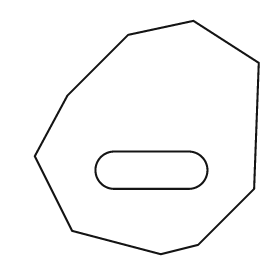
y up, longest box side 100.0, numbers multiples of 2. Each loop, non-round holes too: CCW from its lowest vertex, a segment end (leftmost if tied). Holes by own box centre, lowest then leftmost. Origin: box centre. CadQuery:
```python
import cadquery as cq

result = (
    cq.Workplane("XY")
    .moveTo(6.0, -50.0)
    .lineTo(22.0, -46.0)
    .lineTo(46.0, -22.0)
    .lineTo(48.0, 32.0)
    .lineTo(20.0, 50.0)
    .lineTo(-8.0, 44.0)
    .lineTo(-34.0, 18.0)
    .lineTo(-48.0, -8.0)
    .lineTo(-32.0, -40.0)
    .close()
    .moveTo(-14.0, -22.0)
    .lineTo(18.0, -22.0)
    .threePointArc((26.0, -14.0), (18.0, -6.0))
    .lineTo(-14.0, -6.0)
    .threePointArc((-22.0, -14.0), (-14.0, -22.0))
    .close()
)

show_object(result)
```